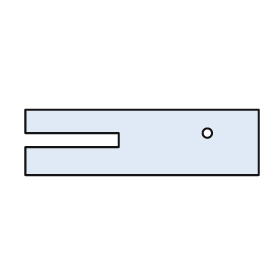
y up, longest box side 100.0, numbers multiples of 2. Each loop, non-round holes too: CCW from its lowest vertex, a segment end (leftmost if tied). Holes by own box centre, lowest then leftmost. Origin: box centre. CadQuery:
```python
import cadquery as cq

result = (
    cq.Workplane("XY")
    .moveTo(-50.0, -14.0)
    .lineTo(50.0, -14.0)
    .lineTo(50.0, 14.0)
    .lineTo(-50.0, 14.0)
    .lineTo(-50.0, 4.0)
    .lineTo(-10.0, 4.0)
    .lineTo(-10.0, -2.0)
    .lineTo(-50.0, -2.0)
    .close()
    .moveTo(28.0, 4.0)
    .circle(2.0)
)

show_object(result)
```